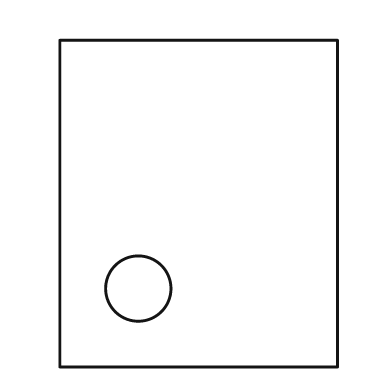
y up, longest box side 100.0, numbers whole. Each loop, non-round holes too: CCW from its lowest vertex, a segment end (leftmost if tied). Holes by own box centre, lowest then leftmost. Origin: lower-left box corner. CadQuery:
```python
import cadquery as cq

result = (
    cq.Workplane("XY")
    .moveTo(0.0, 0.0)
    .lineTo(85.0, 0.0)
    .lineTo(85.0, 100.0)
    .lineTo(0.0, 100.0)
    .close()
    .moveTo(24.0, 24.0)
    .circle(10.0)
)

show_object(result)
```